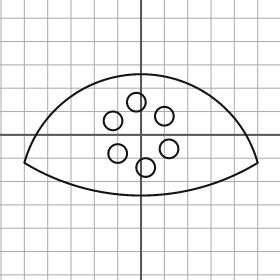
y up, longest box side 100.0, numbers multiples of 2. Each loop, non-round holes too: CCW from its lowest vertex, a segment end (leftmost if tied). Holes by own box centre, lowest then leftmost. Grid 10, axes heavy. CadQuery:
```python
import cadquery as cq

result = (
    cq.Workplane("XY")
    .moveTo(-50.0, -12.0)
    .threePointArc((0.0, -26.0), (50.0, -12.0))
    .threePointArc((0.0, 26.0), (-50.0, -12.0))
    .close()
    .moveTo(2.0, -14.0)
    .circle(4.0)
    .moveTo(-10.0, -8.0)
    .circle(4.0)
    .moveTo(12.0, -6.0)
    .circle(4.0)
    .moveTo(-12.0, 6.0)
    .circle(4.0)
    .moveTo(10.0, 8.0)
    .circle(4.0)
    .moveTo(-2.0, 14.0)
    .circle(4.0)
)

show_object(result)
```